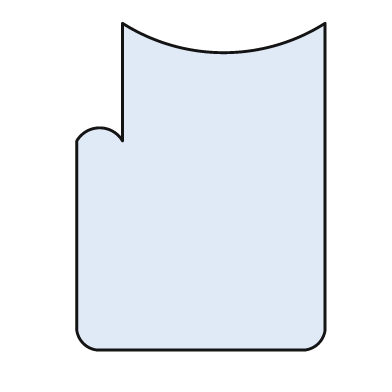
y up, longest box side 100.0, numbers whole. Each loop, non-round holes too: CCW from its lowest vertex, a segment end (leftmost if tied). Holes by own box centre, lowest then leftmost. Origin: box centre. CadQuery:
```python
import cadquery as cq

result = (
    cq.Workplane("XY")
    .moveTo(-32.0, -50.0)
    .lineTo(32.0, -50.0)
    .threePointArc((36.0, -48.0), (38.0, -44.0))
    .lineTo(38.0, 50.0)
    .threePointArc((7.0, 41.0), (-24.0, 50.0))
    .lineTo(-24.0, 14.0)
    .threePointArc((-31.0, 18.0), (-38.0, 14.0))
    .lineTo(-38.0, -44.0)
    .threePointArc((-36.0, -48.0), (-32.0, -50.0))
    .close()
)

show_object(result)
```